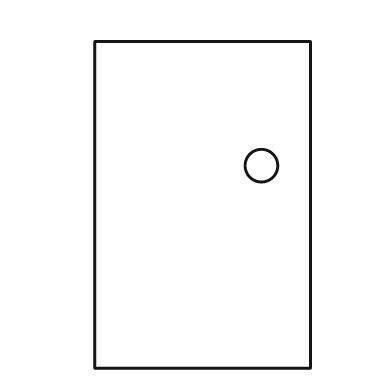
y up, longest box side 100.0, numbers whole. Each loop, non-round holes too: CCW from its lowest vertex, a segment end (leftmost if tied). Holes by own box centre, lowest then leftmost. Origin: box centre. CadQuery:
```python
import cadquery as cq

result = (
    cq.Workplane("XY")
    .moveTo(-33.0, -50.0)
    .lineTo(33.0, -50.0)
    .lineTo(33.0, 50.0)
    .lineTo(-33.0, 50.0)
    .close()
    .moveTo(18.0, 12.0)
    .circle(5.0)
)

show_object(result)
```